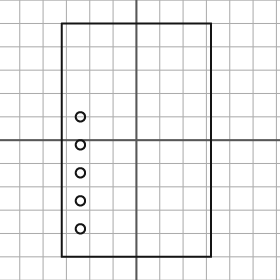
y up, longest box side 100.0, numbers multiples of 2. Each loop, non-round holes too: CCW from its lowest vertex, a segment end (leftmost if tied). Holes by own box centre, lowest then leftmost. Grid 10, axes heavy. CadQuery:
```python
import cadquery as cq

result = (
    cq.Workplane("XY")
    .moveTo(-32.0, -50.0)
    .lineTo(32.0, -50.0)
    .lineTo(32.0, 50.0)
    .lineTo(-32.0, 50.0)
    .close()
    .moveTo(-24.0, -38.0)
    .circle(2.0)
    .moveTo(-24.0, -26.0)
    .circle(2.0)
    .moveTo(-24.0, -14.0)
    .circle(2.0)
    .moveTo(-24.0, -2.0)
    .circle(2.0)
    .moveTo(-24.0, 10.0)
    .circle(2.0)
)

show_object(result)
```